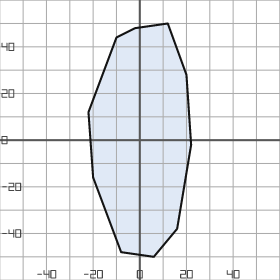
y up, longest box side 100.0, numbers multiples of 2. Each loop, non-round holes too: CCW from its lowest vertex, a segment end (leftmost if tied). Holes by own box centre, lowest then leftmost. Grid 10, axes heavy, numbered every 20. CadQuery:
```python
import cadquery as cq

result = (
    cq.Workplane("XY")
    .moveTo(6.0, -50.0)
    .lineTo(16.0, -38.0)
    .lineTo(22.0, -2.0)
    .lineTo(20.0, 28.0)
    .lineTo(12.0, 50.0)
    .lineTo(-2.0, 48.0)
    .lineTo(-10.0, 44.0)
    .lineTo(-22.0, 12.0)
    .lineTo(-20.0, -16.0)
    .lineTo(-8.0, -48.0)
    .close()
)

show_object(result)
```